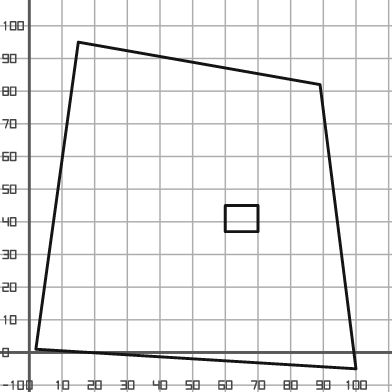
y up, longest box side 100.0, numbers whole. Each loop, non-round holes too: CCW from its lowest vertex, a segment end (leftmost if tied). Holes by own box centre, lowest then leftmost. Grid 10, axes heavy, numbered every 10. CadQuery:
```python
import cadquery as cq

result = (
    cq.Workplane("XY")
    .moveTo(100.0, -5.0)
    .lineTo(89.0, 82.0)
    .lineTo(15.0, 95.0)
    .lineTo(2.0, 1.0)
    .close()
    .moveTo(60.0, 37.0)
    .lineTo(70.0, 37.0)
    .lineTo(70.0, 45.0)
    .lineTo(60.0, 45.0)
    .close()
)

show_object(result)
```